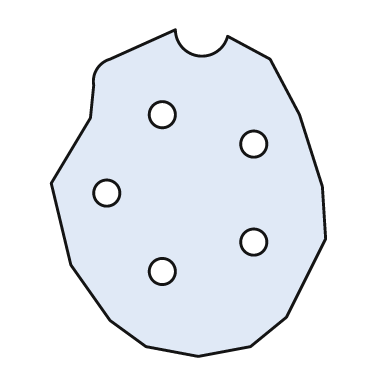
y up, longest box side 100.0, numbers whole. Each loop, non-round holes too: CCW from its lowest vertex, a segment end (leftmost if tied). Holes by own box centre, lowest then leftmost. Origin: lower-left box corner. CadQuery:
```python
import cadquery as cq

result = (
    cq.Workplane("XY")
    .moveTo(45.0, 0.0)
    .lineTo(61.0, 3.0)
    .lineTo(72.0, 12.0)
    .lineTo(84.0, 36.0)
    .lineTo(83.0, 52.0)
    .lineTo(76.0, 74.0)
    .lineTo(67.0, 91.0)
    .lineTo(54.0, 98.0)
    .threePointArc((45.0, 92.0), (38.0, 100.0))
    .lineTo(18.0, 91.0)
    .threePointArc((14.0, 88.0), (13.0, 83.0))
    .lineTo(12.0, 73.0)
    .lineTo(0.0, 53.0)
    .lineTo(6.0, 28.0)
    .lineTo(18.0, 11.0)
    .lineTo(29.0, 3.0)
    .close()
    .moveTo(34.0, 26.0)
    .circle(4.0)
    .moveTo(62.0, 35.0)
    .circle(4.0)
    .moveTo(17.0, 50.0)
    .circle(4.0)
    .moveTo(62.0, 65.0)
    .circle(4.0)
    .moveTo(34.0, 74.0)
    .circle(4.0)
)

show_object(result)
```